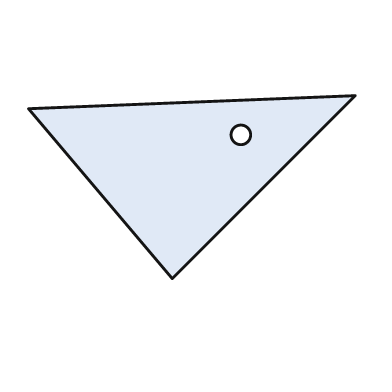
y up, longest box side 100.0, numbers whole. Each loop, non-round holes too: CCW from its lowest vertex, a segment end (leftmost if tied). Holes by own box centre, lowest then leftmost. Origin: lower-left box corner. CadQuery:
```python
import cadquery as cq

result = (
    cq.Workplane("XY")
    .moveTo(44.0, 0.0)
    .lineTo(100.0, 56.0)
    .lineTo(0.0, 52.0)
    .close()
    .moveTo(65.0, 44.0)
    .circle(3.0)
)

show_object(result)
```